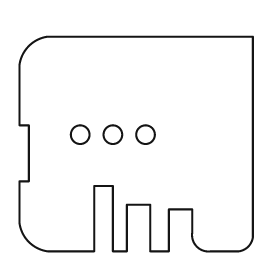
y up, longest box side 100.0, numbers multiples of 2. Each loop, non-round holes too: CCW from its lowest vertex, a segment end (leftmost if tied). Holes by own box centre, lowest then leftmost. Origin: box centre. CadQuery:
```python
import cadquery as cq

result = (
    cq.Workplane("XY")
    .moveTo(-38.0, -46.0)
    .lineTo(-18.0, -46.0)
    .lineTo(-18.0, -18.0)
    .lineTo(-10.0, -18.0)
    .lineTo(-10.0, -46.0)
    .lineTo(-4.0, -46.0)
    .lineTo(-4.0, -26.0)
    .lineTo(6.0, -26.0)
    .lineTo(6.0, -46.0)
    .lineTo(14.0, -46.0)
    .lineTo(14.0, -28.0)
    .lineTo(24.0, -28.0)
    .lineTo(24.0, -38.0)
    .threePointArc((26.0, -44.0), (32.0, -46.0))
    .lineTo(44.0, -46.0)
    .threePointArc((48.0, -44.0), (50.0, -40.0))
    .lineTo(50.0, 46.0)
    .lineTo(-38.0, 46.0)
    .threePointArc((-46.0, 42.0), (-50.0, 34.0))
    .lineTo(-50.0, 8.0)
    .lineTo(-46.0, 8.0)
    .lineTo(-46.0, -16.0)
    .lineTo(-50.0, -16.0)
    .lineTo(-50.0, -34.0)
    .threePointArc((-46.0, -42.0), (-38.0, -46.0))
    .close()
    .moveTo(-24.0, 4.0)
    .circle(4.0)
    .moveTo(-10.0, 4.0)
    .circle(4.0)
    .moveTo(4.0, 4.0)
    .circle(4.0)
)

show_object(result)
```